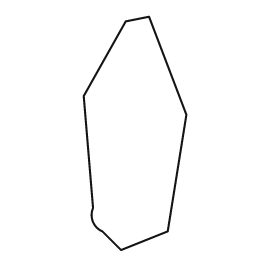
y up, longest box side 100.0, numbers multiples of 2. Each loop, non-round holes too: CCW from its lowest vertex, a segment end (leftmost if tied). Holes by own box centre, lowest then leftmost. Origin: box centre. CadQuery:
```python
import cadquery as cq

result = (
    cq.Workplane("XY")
    .moveTo(-6.0, -50.0)
    .lineTo(14.0, -42.0)
    .lineTo(22.0, 8.0)
    .lineTo(6.0, 50.0)
    .lineTo(-4.0, 48.0)
    .lineTo(-22.0, 16.0)
    .lineTo(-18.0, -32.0)
    .threePointArc((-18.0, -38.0), (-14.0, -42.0))
    .close()
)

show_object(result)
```